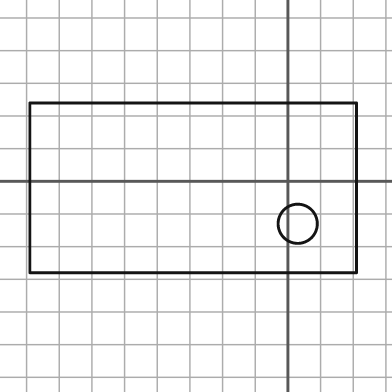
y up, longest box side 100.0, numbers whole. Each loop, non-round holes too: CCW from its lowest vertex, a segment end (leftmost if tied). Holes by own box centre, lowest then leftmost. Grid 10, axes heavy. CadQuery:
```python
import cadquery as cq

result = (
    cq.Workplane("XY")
    .moveTo(-79.0, -28.0)
    .lineTo(21.0, -28.0)
    .lineTo(21.0, 24.0)
    .lineTo(-79.0, 24.0)
    .close()
    .moveTo(3.0, -13.0)
    .circle(6.0)
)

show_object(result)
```